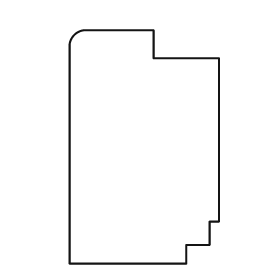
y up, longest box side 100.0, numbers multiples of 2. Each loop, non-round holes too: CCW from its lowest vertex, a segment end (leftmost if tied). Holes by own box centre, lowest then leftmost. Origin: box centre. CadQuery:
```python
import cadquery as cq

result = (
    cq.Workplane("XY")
    .moveTo(-32.0, -50.0)
    .lineTo(18.0, -50.0)
    .lineTo(18.0, -42.0)
    .lineTo(28.0, -42.0)
    .lineTo(28.0, -32.0)
    .lineTo(32.0, -32.0)
    .lineTo(32.0, 38.0)
    .lineTo(4.0, 38.0)
    .lineTo(4.0, 50.0)
    .lineTo(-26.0, 50.0)
    .threePointArc((-30.0, 48.0), (-32.0, 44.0))
    .close()
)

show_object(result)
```